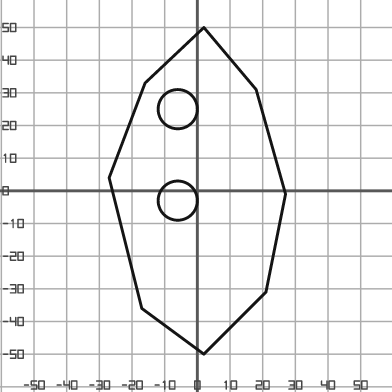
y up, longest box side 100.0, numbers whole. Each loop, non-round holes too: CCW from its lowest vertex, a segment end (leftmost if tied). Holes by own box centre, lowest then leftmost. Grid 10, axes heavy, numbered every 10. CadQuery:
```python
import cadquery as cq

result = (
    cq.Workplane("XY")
    .moveTo(2.0, -50.0)
    .lineTo(21.0, -31.0)
    .lineTo(27.0, -1.0)
    .lineTo(18.0, 31.0)
    .lineTo(2.0, 50.0)
    .lineTo(-16.0, 33.0)
    .lineTo(-27.0, 4.0)
    .lineTo(-17.0, -36.0)
    .close()
    .moveTo(-6.0, -3.0)
    .circle(6.0)
    .moveTo(-6.0, 25.0)
    .circle(6.0)
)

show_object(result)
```